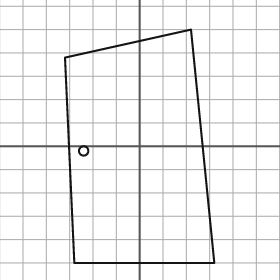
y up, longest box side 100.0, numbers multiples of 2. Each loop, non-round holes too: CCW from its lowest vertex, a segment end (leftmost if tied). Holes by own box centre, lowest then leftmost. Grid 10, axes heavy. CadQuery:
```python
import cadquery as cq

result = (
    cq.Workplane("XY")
    .moveTo(-28.0, -50.0)
    .lineTo(32.0, -50.0)
    .lineTo(22.0, 50.0)
    .lineTo(-32.0, 38.0)
    .close()
    .moveTo(-24.0, -2.0)
    .circle(2.0)
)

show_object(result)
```